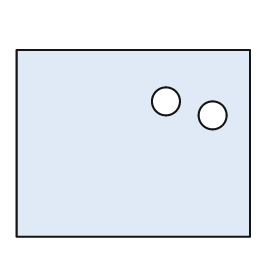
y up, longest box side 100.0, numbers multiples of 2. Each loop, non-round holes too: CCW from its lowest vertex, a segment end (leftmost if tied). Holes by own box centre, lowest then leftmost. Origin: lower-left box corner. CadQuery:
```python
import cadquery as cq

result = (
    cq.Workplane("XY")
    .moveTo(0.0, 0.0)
    .lineTo(100.0, 0.0)
    .lineTo(100.0, 80.0)
    .lineTo(0.0, 80.0)
    .close()
    .moveTo(84.0, 52.0)
    .circle(6.0)
    .moveTo(64.0, 58.0)
    .circle(6.0)
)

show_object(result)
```